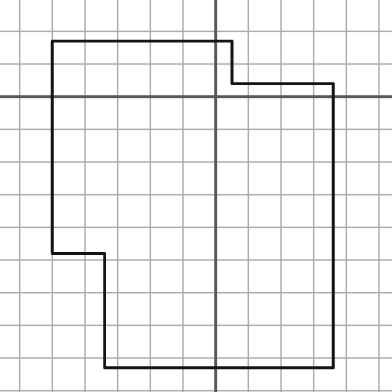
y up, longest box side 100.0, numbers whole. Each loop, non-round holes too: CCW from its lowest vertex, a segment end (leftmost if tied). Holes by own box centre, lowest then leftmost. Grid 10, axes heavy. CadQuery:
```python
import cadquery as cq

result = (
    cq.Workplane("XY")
    .moveTo(-34.0, -83.0)
    .lineTo(36.0, -83.0)
    .lineTo(36.0, 4.0)
    .lineTo(5.0, 4.0)
    .lineTo(5.0, 17.0)
    .lineTo(-50.0, 17.0)
    .lineTo(-50.0, -48.0)
    .lineTo(-34.0, -48.0)
    .close()
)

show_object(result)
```